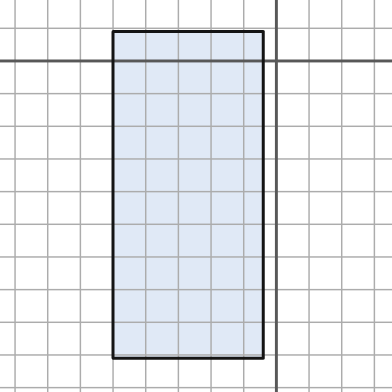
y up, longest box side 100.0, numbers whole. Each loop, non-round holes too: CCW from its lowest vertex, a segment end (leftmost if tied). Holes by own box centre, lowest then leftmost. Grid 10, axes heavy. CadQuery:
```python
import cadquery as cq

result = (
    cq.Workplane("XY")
    .moveTo(-50.0, -91.0)
    .lineTo(-4.0, -91.0)
    .lineTo(-4.0, 9.0)
    .lineTo(-50.0, 9.0)
    .close()
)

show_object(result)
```